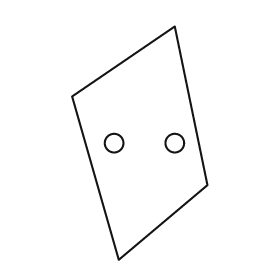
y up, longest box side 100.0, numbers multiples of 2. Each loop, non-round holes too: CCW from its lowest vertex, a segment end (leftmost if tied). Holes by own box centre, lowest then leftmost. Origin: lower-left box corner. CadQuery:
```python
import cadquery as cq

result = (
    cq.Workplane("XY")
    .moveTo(20.0, 0.0)
    .lineTo(58.0, 32.0)
    .lineTo(44.0, 100.0)
    .lineTo(0.0, 70.0)
    .close()
    .moveTo(18.0, 50.0)
    .circle(4.0)
    .moveTo(44.0, 50.0)
    .circle(4.0)
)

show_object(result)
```